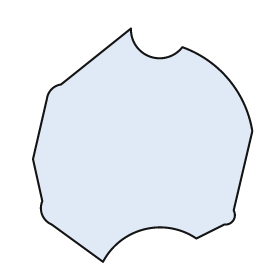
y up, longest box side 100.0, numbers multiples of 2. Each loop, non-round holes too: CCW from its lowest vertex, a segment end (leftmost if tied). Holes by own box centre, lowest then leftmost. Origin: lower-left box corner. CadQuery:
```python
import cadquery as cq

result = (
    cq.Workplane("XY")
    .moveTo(30.0, 0.0)
    .threePointArc((48.0, 14.0), (70.0, 10.0))
    .lineTo(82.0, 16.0)
    .threePointArc((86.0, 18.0), (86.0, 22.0))
    .lineTo(94.0, 56.0)
    .threePointArc((84.0, 78.0), (64.0, 92.0))
    .threePointArc((50.0, 88.0), (42.0, 100.0))
    .lineTo(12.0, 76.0)
    .threePointArc((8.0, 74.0), (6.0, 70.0))
    .lineTo(0.0, 44.0)
    .lineTo(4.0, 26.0)
    .threePointArc((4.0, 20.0), (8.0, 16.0))
    .close()
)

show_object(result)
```